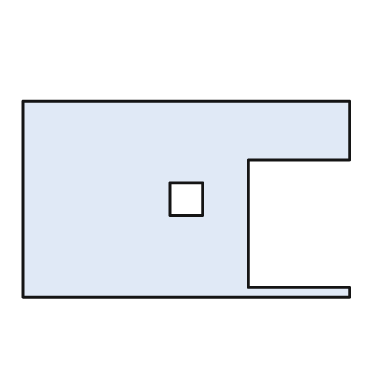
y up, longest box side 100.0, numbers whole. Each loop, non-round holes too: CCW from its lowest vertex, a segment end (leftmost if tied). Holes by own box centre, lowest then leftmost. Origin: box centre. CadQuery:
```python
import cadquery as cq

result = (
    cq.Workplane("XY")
    .moveTo(-50.0, -30.0)
    .lineTo(50.0, -30.0)
    .lineTo(50.0, -27.0)
    .lineTo(19.0, -27.0)
    .lineTo(19.0, 12.0)
    .lineTo(50.0, 12.0)
    .lineTo(50.0, 30.0)
    .lineTo(-50.0, 30.0)
    .close()
    .moveTo(-5.0, -5.0)
    .lineTo(5.0, -5.0)
    .lineTo(5.0, 5.0)
    .lineTo(-5.0, 5.0)
    .close()
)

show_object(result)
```